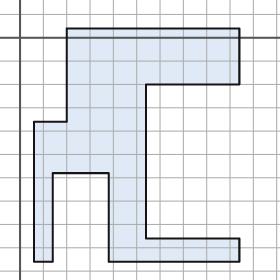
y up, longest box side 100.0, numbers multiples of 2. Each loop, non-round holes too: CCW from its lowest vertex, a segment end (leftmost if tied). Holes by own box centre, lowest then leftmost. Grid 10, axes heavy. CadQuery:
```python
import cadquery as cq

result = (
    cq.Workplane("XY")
    .moveTo(6.0, -96.0)
    .lineTo(14.0, -96.0)
    .lineTo(14.0, -58.0)
    .lineTo(38.0, -58.0)
    .lineTo(38.0, -96.0)
    .lineTo(94.0, -96.0)
    .lineTo(94.0, -86.0)
    .lineTo(54.0, -86.0)
    .lineTo(54.0, -20.0)
    .lineTo(94.0, -20.0)
    .lineTo(94.0, 4.0)
    .lineTo(20.0, 4.0)
    .lineTo(20.0, -36.0)
    .lineTo(6.0, -36.0)
    .close()
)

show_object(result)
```